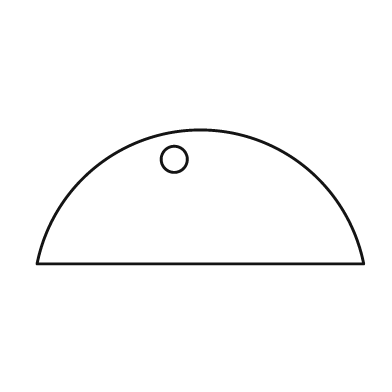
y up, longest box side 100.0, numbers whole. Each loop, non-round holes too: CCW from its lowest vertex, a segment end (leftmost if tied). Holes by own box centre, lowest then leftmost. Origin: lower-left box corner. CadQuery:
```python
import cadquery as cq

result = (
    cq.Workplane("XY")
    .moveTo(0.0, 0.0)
    .lineTo(100.0, 0.0)
    .threePointArc((50.0, 41.0), (0.0, 0.0))
    .close()
    .moveTo(42.0, 32.0)
    .circle(4.0)
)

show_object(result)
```